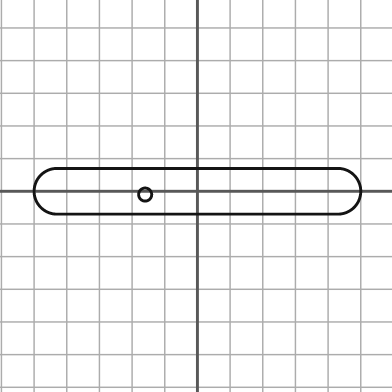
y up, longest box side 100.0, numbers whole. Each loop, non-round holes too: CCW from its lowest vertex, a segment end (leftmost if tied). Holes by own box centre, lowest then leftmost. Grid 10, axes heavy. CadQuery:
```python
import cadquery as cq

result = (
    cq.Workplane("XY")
    .moveTo(-43.0, -7.0)
    .lineTo(43.0, -7.0)
    .threePointArc((50.0, 0.0), (43.0, 7.0))
    .lineTo(-43.0, 7.0)
    .threePointArc((-50.0, 0.0), (-43.0, -7.0))
    .close()
    .moveTo(-16.0, -1.0)
    .circle(2.0)
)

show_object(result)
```